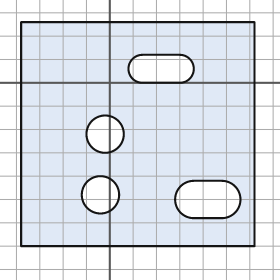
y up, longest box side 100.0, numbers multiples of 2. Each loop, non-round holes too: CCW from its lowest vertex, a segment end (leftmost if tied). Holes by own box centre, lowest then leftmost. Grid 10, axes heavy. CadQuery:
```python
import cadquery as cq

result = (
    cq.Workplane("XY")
    .moveTo(-38.0, -70.0)
    .lineTo(62.0, -70.0)
    .lineTo(62.0, 26.0)
    .lineTo(-38.0, 26.0)
    .close()
    .moveTo(36.0, -58.0)
    .lineTo(48.0, -58.0)
    .threePointArc((56.0, -50.0), (48.0, -42.0))
    .lineTo(36.0, -42.0)
    .threePointArc((28.0, -50.0), (36.0, -58.0))
    .close()
    .moveTo(-4.0, -48.0)
    .circle(8.0)
    .moveTo(-2.0, -22.0)
    .circle(8.0)
    .moveTo(14.0, 0.0)
    .lineTo(30.0, 0.0)
    .threePointArc((36.0, 6.0), (30.0, 12.0))
    .lineTo(14.0, 12.0)
    .threePointArc((8.0, 6.0), (14.0, 0.0))
    .close()
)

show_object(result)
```